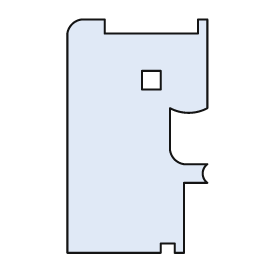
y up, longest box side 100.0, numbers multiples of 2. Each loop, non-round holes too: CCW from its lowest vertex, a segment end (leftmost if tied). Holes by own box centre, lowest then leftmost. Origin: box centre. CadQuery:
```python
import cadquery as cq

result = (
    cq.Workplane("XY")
    .moveTo(-30.0, -50.0)
    .lineTo(10.0, -50.0)
    .lineTo(10.0, -46.0)
    .lineTo(16.0, -46.0)
    .lineTo(16.0, -50.0)
    .lineTo(20.0, -50.0)
    .lineTo(20.0, -20.0)
    .lineTo(30.0, -20.0)
    .threePointArc((28.0, -16.0), (30.0, -12.0))
    .lineTo(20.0, -12.0)
    .threePointArc((16.0, -10.0), (14.0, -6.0))
    .lineTo(14.0, 12.0)
    .threePointArc((22.0, 10.0), (30.0, 12.0))
    .lineTo(30.0, 50.0)
    .lineTo(26.0, 50.0)
    .lineTo(26.0, 44.0)
    .lineTo(-14.0, 44.0)
    .lineTo(-14.0, 50.0)
    .lineTo(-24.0, 50.0)
    .threePointArc((-28.0, 48.0), (-30.0, 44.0))
    .close()
    .moveTo(2.0, 20.0)
    .lineTo(10.0, 20.0)
    .lineTo(10.0, 28.0)
    .lineTo(2.0, 28.0)
    .close()
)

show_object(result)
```